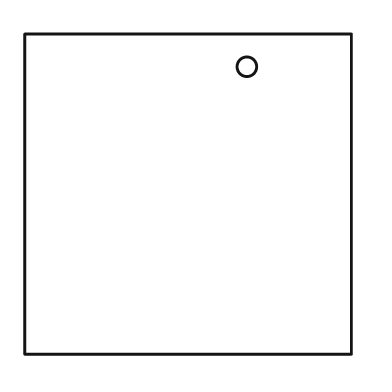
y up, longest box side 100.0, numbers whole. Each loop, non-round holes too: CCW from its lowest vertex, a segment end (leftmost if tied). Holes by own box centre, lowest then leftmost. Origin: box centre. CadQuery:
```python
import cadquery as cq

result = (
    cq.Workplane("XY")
    .moveTo(-50.0, -49.0)
    .lineTo(50.0, -49.0)
    .lineTo(50.0, 49.0)
    .lineTo(-50.0, 49.0)
    .close()
    .moveTo(18.0, 39.0)
    .circle(3.0)
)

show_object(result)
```